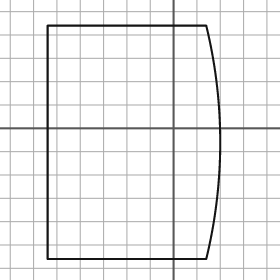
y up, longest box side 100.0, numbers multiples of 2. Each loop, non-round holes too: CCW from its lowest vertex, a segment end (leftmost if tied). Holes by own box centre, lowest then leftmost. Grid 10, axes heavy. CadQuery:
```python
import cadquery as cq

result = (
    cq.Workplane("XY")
    .moveTo(-54.0, -56.0)
    .lineTo(14.0, -56.0)
    .threePointArc((20.0, -6.0), (14.0, 44.0))
    .lineTo(-54.0, 44.0)
    .close()
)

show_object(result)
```